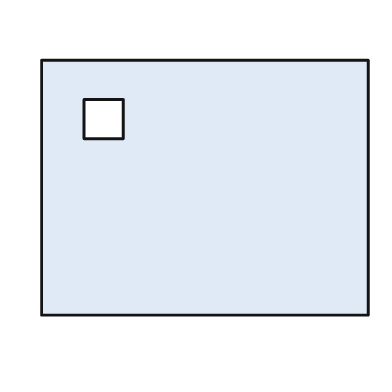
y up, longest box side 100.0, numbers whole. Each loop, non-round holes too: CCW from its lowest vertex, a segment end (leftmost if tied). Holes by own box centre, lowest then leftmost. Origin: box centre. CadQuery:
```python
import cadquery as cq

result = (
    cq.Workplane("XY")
    .moveTo(-50.0, -39.0)
    .lineTo(50.0, -39.0)
    .lineTo(50.0, 39.0)
    .lineTo(-50.0, 39.0)
    .close()
    .moveTo(-37.0, 15.0)
    .lineTo(-25.0, 15.0)
    .lineTo(-25.0, 27.0)
    .lineTo(-37.0, 27.0)
    .close()
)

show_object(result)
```